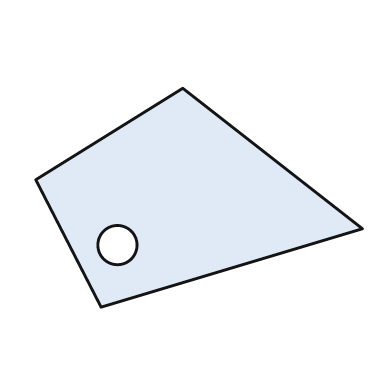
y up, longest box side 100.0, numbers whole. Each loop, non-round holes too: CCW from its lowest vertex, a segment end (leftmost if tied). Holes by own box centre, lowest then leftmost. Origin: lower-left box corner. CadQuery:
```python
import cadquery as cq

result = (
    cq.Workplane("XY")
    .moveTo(20.0, 0.0)
    .lineTo(100.0, 24.0)
    .lineTo(45.0, 67.0)
    .lineTo(0.0, 39.0)
    .close()
    .moveTo(25.0, 19.0)
    .circle(6.0)
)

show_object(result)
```